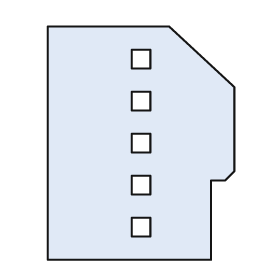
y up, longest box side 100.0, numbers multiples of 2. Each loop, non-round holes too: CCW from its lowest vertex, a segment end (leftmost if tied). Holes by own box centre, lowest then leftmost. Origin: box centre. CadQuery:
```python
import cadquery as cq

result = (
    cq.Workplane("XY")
    .moveTo(-40.0, -50.0)
    .lineTo(30.0, -50.0)
    .lineTo(30.0, -16.0)
    .lineTo(36.0, -16.0)
    .lineTo(40.0, -12.0)
    .lineTo(40.0, 24.0)
    .lineTo(12.0, 50.0)
    .lineTo(-40.0, 50.0)
    .close()
    .moveTo(-4.0, -40.0)
    .lineTo(4.0, -40.0)
    .lineTo(4.0, -32.0)
    .lineTo(-4.0, -32.0)
    .close()
    .moveTo(-4.0, -22.0)
    .lineTo(4.0, -22.0)
    .lineTo(4.0, -14.0)
    .lineTo(-4.0, -14.0)
    .close()
    .moveTo(-4.0, -4.0)
    .lineTo(4.0, -4.0)
    .lineTo(4.0, 4.0)
    .lineTo(-4.0, 4.0)
    .close()
    .moveTo(-4.0, 14.0)
    .lineTo(4.0, 14.0)
    .lineTo(4.0, 22.0)
    .lineTo(-4.0, 22.0)
    .close()
    .moveTo(-4.0, 32.0)
    .lineTo(4.0, 32.0)
    .lineTo(4.0, 40.0)
    .lineTo(-4.0, 40.0)
    .close()
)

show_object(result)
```